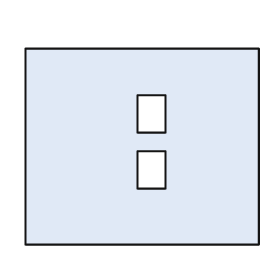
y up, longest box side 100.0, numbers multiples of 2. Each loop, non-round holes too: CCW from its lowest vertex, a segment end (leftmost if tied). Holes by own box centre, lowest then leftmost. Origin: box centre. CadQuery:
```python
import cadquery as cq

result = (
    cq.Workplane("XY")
    .moveTo(-50.0, -42.0)
    .lineTo(50.0, -42.0)
    .lineTo(50.0, 42.0)
    .lineTo(-50.0, 42.0)
    .close()
    .moveTo(-2.0, -18.0)
    .lineTo(10.0, -18.0)
    .lineTo(10.0, -2.0)
    .lineTo(-2.0, -2.0)
    .close()
    .moveTo(-2.0, 6.0)
    .lineTo(10.0, 6.0)
    .lineTo(10.0, 22.0)
    .lineTo(-2.0, 22.0)
    .close()
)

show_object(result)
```